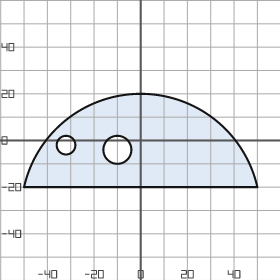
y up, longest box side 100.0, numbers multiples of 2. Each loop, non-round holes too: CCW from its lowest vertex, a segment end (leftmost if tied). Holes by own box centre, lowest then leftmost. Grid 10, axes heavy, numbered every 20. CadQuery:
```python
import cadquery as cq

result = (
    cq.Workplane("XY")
    .moveTo(-50.0, -20.0)
    .lineTo(50.0, -20.0)
    .threePointArc((0.0, 20.0), (-50.0, -20.0))
    .close()
    .moveTo(-10.0, -4.0)
    .circle(6.0)
    .moveTo(-32.0, -2.0)
    .circle(4.0)
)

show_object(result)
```